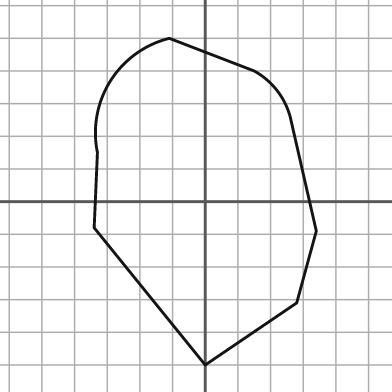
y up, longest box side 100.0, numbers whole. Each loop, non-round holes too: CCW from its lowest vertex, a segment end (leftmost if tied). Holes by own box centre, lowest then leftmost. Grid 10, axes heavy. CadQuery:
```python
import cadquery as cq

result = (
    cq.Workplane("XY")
    .moveTo(0.0, -50.0)
    .lineTo(28.0, -31.0)
    .lineTo(34.0, -9.0)
    .lineTo(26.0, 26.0)
    .threePointArc((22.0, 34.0), (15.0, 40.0))
    .lineTo(-11.0, 50.0)
    .threePointArc((-29.0, 37.0), (-33.0, 15.0))
    .lineTo(-34.0, -8.0)
    .close()
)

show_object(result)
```